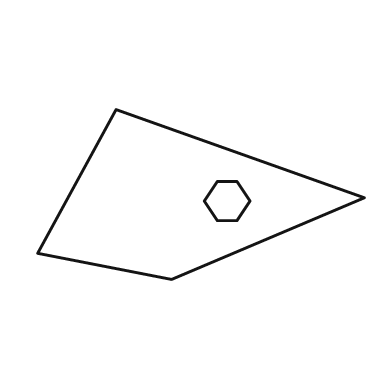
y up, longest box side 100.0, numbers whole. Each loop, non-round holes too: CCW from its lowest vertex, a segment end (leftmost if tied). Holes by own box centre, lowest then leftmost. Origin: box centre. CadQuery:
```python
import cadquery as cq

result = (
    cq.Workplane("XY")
    .moveTo(-9.0, -26.0)
    .lineTo(50.0, -1.0)
    .lineTo(-26.0, 26.0)
    .lineTo(-50.0, -18.0)
    .close()
    .moveTo(5.0, -8.0)
    .lineTo(11.0, -8.0)
    .lineTo(15.0, -2.0)
    .lineTo(11.0, 4.0)
    .lineTo(5.0, 4.0)
    .lineTo(1.0, -2.0)
    .close()
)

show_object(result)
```